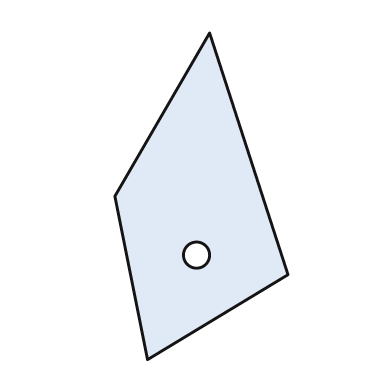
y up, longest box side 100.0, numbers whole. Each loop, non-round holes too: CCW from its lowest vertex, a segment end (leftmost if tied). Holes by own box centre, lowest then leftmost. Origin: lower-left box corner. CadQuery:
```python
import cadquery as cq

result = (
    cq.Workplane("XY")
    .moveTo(10.0, 0.0)
    .lineTo(53.0, 26.0)
    .lineTo(29.0, 100.0)
    .lineTo(0.0, 50.0)
    .close()
    .moveTo(25.0, 32.0)
    .circle(4.0)
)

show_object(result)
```